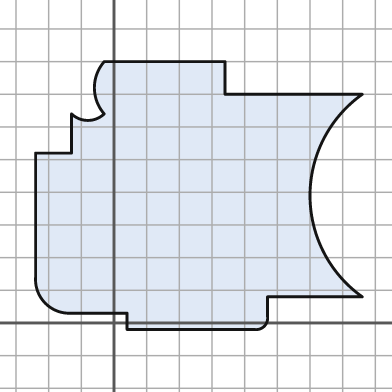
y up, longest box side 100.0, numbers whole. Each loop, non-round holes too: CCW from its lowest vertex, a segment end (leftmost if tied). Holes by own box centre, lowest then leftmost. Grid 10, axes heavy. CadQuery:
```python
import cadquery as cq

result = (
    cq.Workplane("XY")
    .moveTo(4.0, -2.0)
    .lineTo(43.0, -2.0)
    .threePointArc((46.0, -1.0), (47.0, 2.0))
    .lineTo(47.0, 8.0)
    .lineTo(76.0, 8.0)
    .threePointArc((60.0, 39.0), (76.0, 70.0))
    .lineTo(34.0, 70.0)
    .lineTo(34.0, 80.0)
    .lineTo(-3.0, 80.0)
    .threePointArc((-6.0, 72.0), (-3.0, 64.0))
    .threePointArc((-8.0, 62.0), (-13.0, 64.0))
    .lineTo(-13.0, 52.0)
    .lineTo(-24.0, 52.0)
    .lineTo(-24.0, 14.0)
    .threePointArc((-21.0, 6.0), (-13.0, 3.0))
    .lineTo(4.0, 3.0)
    .close()
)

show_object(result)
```